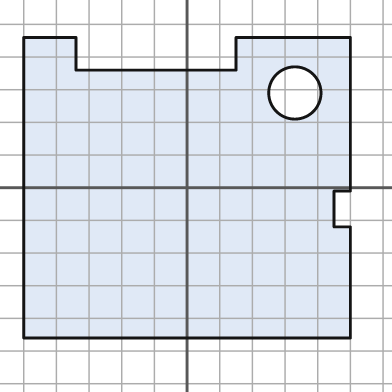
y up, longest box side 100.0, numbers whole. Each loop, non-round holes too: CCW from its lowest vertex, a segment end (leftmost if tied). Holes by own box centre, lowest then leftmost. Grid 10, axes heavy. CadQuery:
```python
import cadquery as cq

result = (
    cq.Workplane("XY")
    .moveTo(-50.0, -46.0)
    .lineTo(50.0, -46.0)
    .lineTo(50.0, -12.0)
    .lineTo(45.0, -12.0)
    .lineTo(45.0, -1.0)
    .lineTo(50.0, -1.0)
    .lineTo(50.0, 46.0)
    .lineTo(15.0, 46.0)
    .lineTo(15.0, 36.0)
    .lineTo(-34.0, 36.0)
    .lineTo(-34.0, 46.0)
    .lineTo(-50.0, 46.0)
    .close()
    .moveTo(33.0, 29.0)
    .circle(8.0)
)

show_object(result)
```